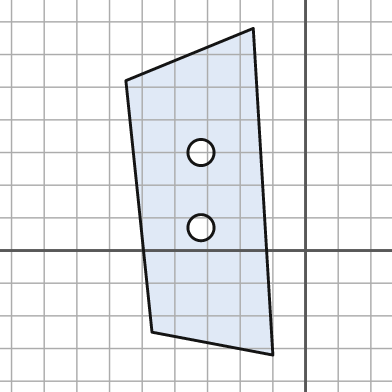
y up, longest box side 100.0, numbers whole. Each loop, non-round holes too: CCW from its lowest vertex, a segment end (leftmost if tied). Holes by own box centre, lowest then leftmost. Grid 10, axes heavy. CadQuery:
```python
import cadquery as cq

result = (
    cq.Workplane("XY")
    .moveTo(-10.0, -32.0)
    .lineTo(-16.0, 68.0)
    .lineTo(-55.0, 52.0)
    .lineTo(-47.0, -25.0)
    .close()
    .moveTo(-32.0, 7.0)
    .circle(4.0)
    .moveTo(-32.0, 30.0)
    .circle(4.0)
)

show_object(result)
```